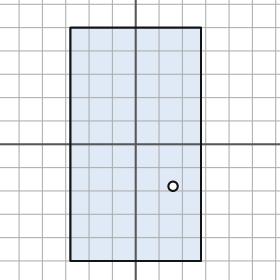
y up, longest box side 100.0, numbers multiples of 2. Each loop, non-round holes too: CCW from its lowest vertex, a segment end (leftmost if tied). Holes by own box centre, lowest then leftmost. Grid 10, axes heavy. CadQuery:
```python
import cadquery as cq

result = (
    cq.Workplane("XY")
    .moveTo(-28.0, -50.0)
    .lineTo(28.0, -50.0)
    .lineTo(28.0, 50.0)
    .lineTo(-28.0, 50.0)
    .close()
    .moveTo(16.0, -18.0)
    .circle(2.0)
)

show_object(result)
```